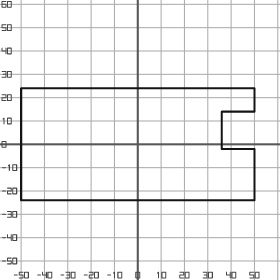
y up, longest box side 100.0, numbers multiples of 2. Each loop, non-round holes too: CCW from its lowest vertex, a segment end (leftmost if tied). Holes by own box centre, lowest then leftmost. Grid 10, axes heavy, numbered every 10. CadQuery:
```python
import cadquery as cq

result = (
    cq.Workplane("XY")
    .moveTo(-50.0, -24.0)
    .lineTo(50.0, -24.0)
    .lineTo(50.0, -2.0)
    .lineTo(36.0, -2.0)
    .lineTo(36.0, 14.0)
    .lineTo(50.0, 14.0)
    .lineTo(50.0, 24.0)
    .lineTo(-50.0, 24.0)
    .close()
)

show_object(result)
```